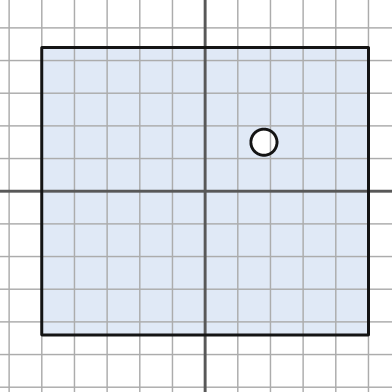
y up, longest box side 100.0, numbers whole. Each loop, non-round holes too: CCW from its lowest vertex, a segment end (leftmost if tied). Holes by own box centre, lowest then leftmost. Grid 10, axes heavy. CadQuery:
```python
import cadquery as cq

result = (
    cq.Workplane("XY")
    .moveTo(-50.0, -44.0)
    .lineTo(50.0, -44.0)
    .lineTo(50.0, 44.0)
    .lineTo(-50.0, 44.0)
    .close()
    .moveTo(18.0, 15.0)
    .circle(4.0)
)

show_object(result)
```